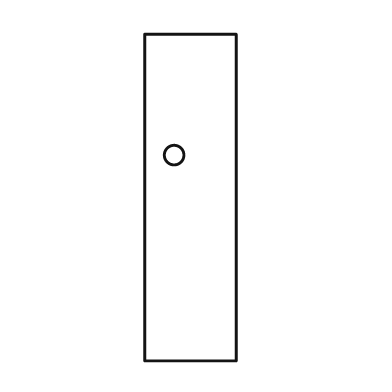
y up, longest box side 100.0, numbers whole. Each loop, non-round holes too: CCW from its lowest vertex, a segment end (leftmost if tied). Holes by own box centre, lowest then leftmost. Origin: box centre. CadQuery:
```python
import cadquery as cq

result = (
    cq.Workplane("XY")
    .moveTo(-14.0, -50.0)
    .lineTo(14.0, -50.0)
    .lineTo(14.0, 50.0)
    .lineTo(-14.0, 50.0)
    .close()
    .moveTo(-5.0, 13.0)
    .circle(3.0)
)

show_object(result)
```